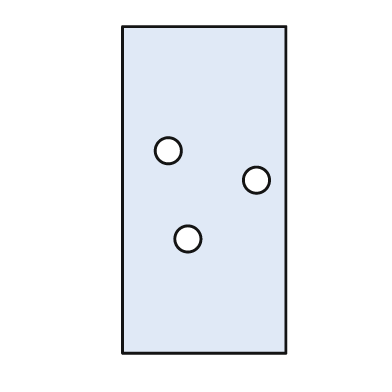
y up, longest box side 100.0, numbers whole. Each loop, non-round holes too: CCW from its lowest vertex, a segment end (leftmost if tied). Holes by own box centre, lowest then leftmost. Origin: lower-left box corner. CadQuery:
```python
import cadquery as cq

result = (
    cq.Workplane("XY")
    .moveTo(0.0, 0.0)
    .lineTo(50.0, 0.0)
    .lineTo(50.0, 100.0)
    .lineTo(0.0, 100.0)
    .close()
    .moveTo(20.0, 35.0)
    .circle(4.0)
    .moveTo(41.0, 53.0)
    .circle(4.0)
    .moveTo(14.0, 62.0)
    .circle(4.0)
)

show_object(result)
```